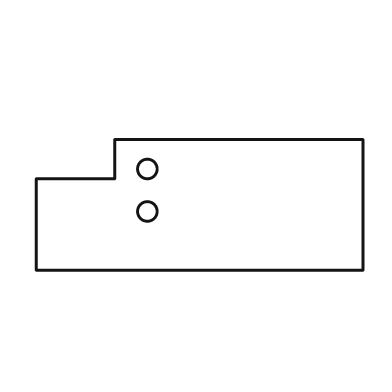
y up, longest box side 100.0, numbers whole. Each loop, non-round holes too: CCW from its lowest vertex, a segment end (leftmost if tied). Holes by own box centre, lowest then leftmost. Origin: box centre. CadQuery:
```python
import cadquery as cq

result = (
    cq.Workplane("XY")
    .moveTo(-50.0, -20.0)
    .lineTo(50.0, -20.0)
    .lineTo(50.0, 20.0)
    .lineTo(-26.0, 20.0)
    .lineTo(-26.0, 8.0)
    .lineTo(-50.0, 8.0)
    .close()
    .moveTo(-16.0, -2.0)
    .circle(3.0)
    .moveTo(-16.0, 11.0)
    .circle(3.0)
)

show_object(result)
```